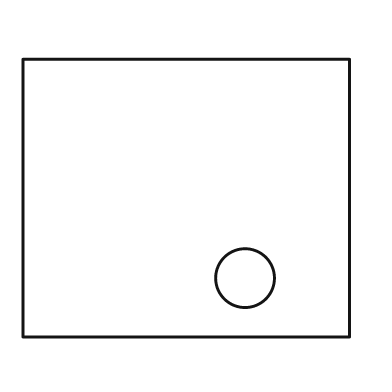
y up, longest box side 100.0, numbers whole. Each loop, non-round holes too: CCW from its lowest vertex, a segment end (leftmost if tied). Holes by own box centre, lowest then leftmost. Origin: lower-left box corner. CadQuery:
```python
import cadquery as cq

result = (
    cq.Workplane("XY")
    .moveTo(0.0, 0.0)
    .lineTo(100.0, 0.0)
    .lineTo(100.0, 85.0)
    .lineTo(0.0, 85.0)
    .close()
    .moveTo(68.0, 18.0)
    .circle(9.0)
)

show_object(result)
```